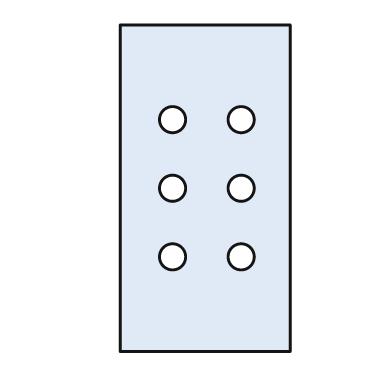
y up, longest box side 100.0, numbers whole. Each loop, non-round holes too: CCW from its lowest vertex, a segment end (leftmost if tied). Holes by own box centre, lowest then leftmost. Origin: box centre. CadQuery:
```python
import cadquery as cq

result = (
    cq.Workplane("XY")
    .moveTo(-26.0, -50.0)
    .lineTo(26.0, -50.0)
    .lineTo(26.0, 50.0)
    .lineTo(-26.0, 50.0)
    .close()
    .moveTo(-10.0, -21.0)
    .circle(4.0)
    .moveTo(11.0, -21.0)
    .circle(4.0)
    .moveTo(-10.0, 0.0)
    .circle(4.0)
    .moveTo(11.0, 0.0)
    .circle(4.0)
    .moveTo(-10.0, 21.0)
    .circle(4.0)
    .moveTo(11.0, 21.0)
    .circle(4.0)
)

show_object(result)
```